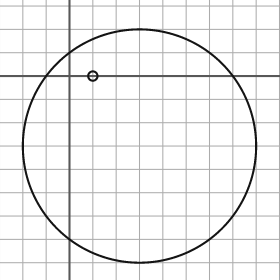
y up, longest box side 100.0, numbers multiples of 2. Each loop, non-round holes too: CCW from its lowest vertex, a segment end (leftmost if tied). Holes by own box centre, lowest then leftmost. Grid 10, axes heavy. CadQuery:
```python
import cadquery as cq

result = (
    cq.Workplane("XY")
    .moveTo(30.0, -30.0)
    .circle(50.0)
    .moveTo(10.0, 0.0)
    .circle(2.0)
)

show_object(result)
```